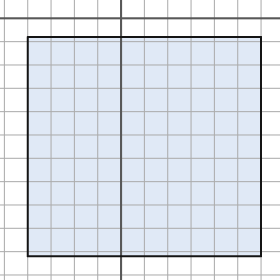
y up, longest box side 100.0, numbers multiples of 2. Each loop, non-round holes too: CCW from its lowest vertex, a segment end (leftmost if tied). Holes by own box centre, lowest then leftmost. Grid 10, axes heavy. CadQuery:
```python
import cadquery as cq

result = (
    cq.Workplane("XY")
    .moveTo(-40.0, -102.0)
    .lineTo(60.0, -102.0)
    .lineTo(60.0, -8.0)
    .lineTo(-40.0, -8.0)
    .close()
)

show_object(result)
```